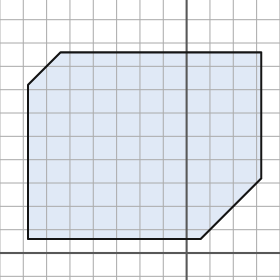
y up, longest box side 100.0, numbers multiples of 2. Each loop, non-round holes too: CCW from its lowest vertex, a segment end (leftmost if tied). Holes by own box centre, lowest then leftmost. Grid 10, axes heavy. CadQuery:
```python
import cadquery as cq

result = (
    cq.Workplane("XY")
    .moveTo(-68.0, 6.0)
    .lineTo(6.0, 6.0)
    .lineTo(32.0, 32.0)
    .lineTo(32.0, 86.0)
    .lineTo(-54.0, 86.0)
    .lineTo(-68.0, 72.0)
    .close()
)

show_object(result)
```